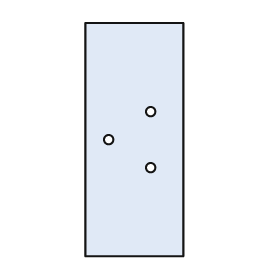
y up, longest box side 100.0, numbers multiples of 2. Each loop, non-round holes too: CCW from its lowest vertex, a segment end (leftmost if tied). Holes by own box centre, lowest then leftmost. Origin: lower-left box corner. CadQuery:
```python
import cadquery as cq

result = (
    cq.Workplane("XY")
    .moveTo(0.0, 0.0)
    .lineTo(42.0, 0.0)
    .lineTo(42.0, 100.0)
    .lineTo(0.0, 100.0)
    .close()
    .moveTo(28.0, 38.0)
    .circle(2.0)
    .moveTo(10.0, 50.0)
    .circle(2.0)
    .moveTo(28.0, 62.0)
    .circle(2.0)
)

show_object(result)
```